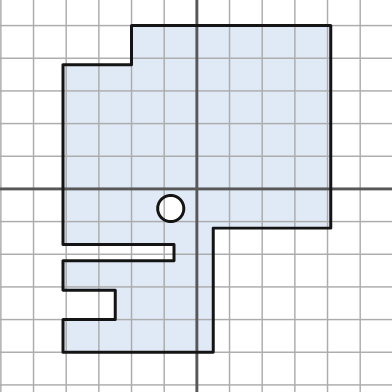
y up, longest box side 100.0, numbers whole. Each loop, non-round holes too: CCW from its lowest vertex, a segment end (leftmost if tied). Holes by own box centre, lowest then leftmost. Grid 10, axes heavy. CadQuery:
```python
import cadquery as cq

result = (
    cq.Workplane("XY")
    .moveTo(-41.0, -50.0)
    .lineTo(5.0, -50.0)
    .lineTo(5.0, -12.0)
    .lineTo(41.0, -12.0)
    .lineTo(41.0, 50.0)
    .lineTo(-20.0, 50.0)
    .lineTo(-20.0, 38.0)
    .lineTo(-41.0, 38.0)
    .lineTo(-41.0, -17.0)
    .lineTo(-7.0, -17.0)
    .lineTo(-7.0, -22.0)
    .lineTo(-41.0, -22.0)
    .lineTo(-41.0, -31.0)
    .lineTo(-25.0, -31.0)
    .lineTo(-25.0, -40.0)
    .lineTo(-41.0, -40.0)
    .close()
    .moveTo(-8.0, -6.0)
    .circle(4.0)
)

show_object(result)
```